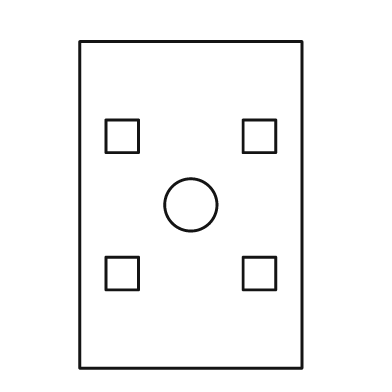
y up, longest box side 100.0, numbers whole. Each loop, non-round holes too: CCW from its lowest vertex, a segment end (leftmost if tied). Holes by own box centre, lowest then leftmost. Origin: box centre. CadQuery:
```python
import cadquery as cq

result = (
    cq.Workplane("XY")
    .moveTo(-34.0, -50.0)
    .lineTo(34.0, -50.0)
    .lineTo(34.0, 50.0)
    .lineTo(-34.0, 50.0)
    .close()
    .moveTo(-26.0, -26.0)
    .lineTo(-16.0, -26.0)
    .lineTo(-16.0, -16.0)
    .lineTo(-26.0, -16.0)
    .close()
    .moveTo(16.0, -26.0)
    .lineTo(26.0, -26.0)
    .lineTo(26.0, -16.0)
    .lineTo(16.0, -16.0)
    .close()
    .moveTo(0.0, 0.0)
    .circle(8.0)
    .moveTo(-26.0, 16.0)
    .lineTo(-16.0, 16.0)
    .lineTo(-16.0, 26.0)
    .lineTo(-26.0, 26.0)
    .close()
    .moveTo(16.0, 16.0)
    .lineTo(26.0, 16.0)
    .lineTo(26.0, 26.0)
    .lineTo(16.0, 26.0)
    .close()
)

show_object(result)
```